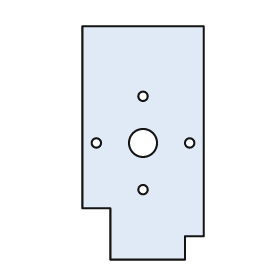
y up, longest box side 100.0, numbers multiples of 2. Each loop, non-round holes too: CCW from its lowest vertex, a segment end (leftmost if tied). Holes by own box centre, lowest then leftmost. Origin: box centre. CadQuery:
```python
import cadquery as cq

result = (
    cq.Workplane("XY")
    .moveTo(-14.0, -50.0)
    .lineTo(18.0, -50.0)
    .lineTo(18.0, -40.0)
    .lineTo(26.0, -40.0)
    .lineTo(26.0, 50.0)
    .lineTo(-26.0, 50.0)
    .lineTo(-26.0, -28.0)
    .lineTo(-14.0, -28.0)
    .close()
    .moveTo(0.0, -20.0)
    .circle(2.0)
    .moveTo(-20.0, 0.0)
    .circle(2.0)
    .moveTo(0.0, 0.0)
    .circle(6.0)
    .moveTo(20.0, 0.0)
    .circle(2.0)
    .moveTo(0.0, 20.0)
    .circle(2.0)
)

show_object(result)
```